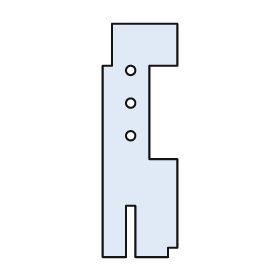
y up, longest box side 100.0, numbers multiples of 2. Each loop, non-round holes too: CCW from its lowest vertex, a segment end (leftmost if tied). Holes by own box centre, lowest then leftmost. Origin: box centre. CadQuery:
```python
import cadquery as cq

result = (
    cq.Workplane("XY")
    .moveTo(-16.0, -50.0)
    .lineTo(-6.0, -50.0)
    .lineTo(-6.0, -28.0)
    .lineTo(-2.0, -28.0)
    .lineTo(-2.0, -50.0)
    .lineTo(12.0, -50.0)
    .lineTo(12.0, -46.0)
    .lineTo(16.0, -46.0)
    .lineTo(16.0, -8.0)
    .lineTo(4.0, -8.0)
    .lineTo(4.0, 32.0)
    .lineTo(16.0, 32.0)
    .lineTo(16.0, 50.0)
    .lineTo(-12.0, 50.0)
    .lineTo(-12.0, 32.0)
    .lineTo(-16.0, 32.0)
    .close()
    .moveTo(-4.0, 2.0)
    .circle(2.0)
    .moveTo(-4.0, 16.0)
    .circle(2.0)
    .moveTo(-4.0, 30.0)
    .circle(2.0)
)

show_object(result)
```